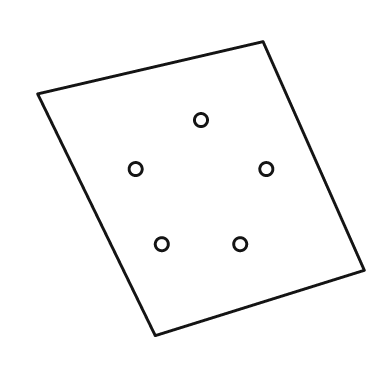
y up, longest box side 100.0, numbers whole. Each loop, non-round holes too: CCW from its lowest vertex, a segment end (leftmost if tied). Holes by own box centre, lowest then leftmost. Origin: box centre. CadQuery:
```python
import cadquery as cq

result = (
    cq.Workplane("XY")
    .moveTo(-14.0, -45.0)
    .lineTo(50.0, -25.0)
    .lineTo(19.0, 45.0)
    .lineTo(-50.0, 29.0)
    .close()
    .moveTo(-12.0, -17.0)
    .circle(2.0)
    .moveTo(12.0, -17.0)
    .circle(2.0)
    .moveTo(-20.0, 6.0)
    .circle(2.0)
    .moveTo(20.0, 6.0)
    .circle(2.0)
    .moveTo(0.0, 21.0)
    .circle(2.0)
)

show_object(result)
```